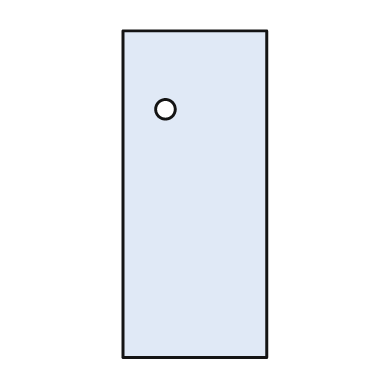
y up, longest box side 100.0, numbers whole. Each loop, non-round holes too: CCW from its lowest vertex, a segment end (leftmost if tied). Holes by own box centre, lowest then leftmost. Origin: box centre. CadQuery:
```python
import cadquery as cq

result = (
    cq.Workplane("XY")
    .moveTo(-22.0, -50.0)
    .lineTo(22.0, -50.0)
    .lineTo(22.0, 50.0)
    .lineTo(-22.0, 50.0)
    .close()
    .moveTo(-9.0, 26.0)
    .circle(3.0)
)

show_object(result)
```